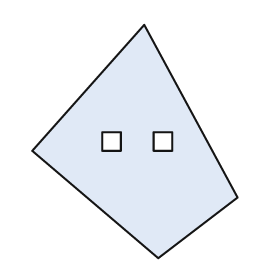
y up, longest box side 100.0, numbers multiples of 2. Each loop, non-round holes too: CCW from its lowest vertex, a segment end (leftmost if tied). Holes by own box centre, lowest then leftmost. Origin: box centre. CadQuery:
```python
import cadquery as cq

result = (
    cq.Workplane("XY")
    .moveTo(10.0, -50.0)
    .lineTo(44.0, -24.0)
    .lineTo(4.0, 50.0)
    .lineTo(-44.0, -4.0)
    .close()
    .moveTo(-14.0, -4.0)
    .lineTo(-6.0, -4.0)
    .lineTo(-6.0, 4.0)
    .lineTo(-14.0, 4.0)
    .close()
    .moveTo(8.0, -4.0)
    .lineTo(16.0, -4.0)
    .lineTo(16.0, 4.0)
    .lineTo(8.0, 4.0)
    .close()
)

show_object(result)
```